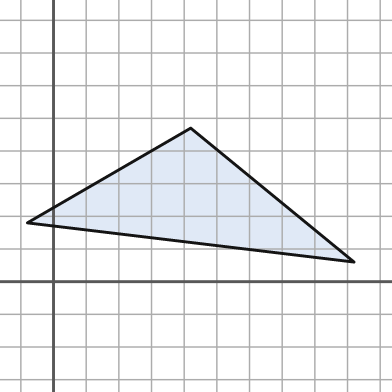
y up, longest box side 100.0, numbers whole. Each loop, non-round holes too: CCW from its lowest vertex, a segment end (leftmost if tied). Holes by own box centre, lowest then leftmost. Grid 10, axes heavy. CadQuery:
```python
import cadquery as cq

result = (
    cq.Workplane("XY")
    .moveTo(92.0, 6.0)
    .lineTo(42.0, 47.0)
    .lineTo(-8.0, 18.0)
    .close()
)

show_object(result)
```